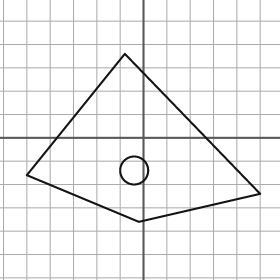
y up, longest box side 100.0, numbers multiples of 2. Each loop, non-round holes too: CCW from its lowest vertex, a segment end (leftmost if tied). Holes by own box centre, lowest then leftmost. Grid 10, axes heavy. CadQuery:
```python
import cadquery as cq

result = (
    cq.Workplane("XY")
    .moveTo(-2.0, -36.0)
    .lineTo(50.0, -24.0)
    .lineTo(-8.0, 36.0)
    .lineTo(-50.0, -16.0)
    .close()
    .moveTo(-4.0, -14.0)
    .circle(6.0)
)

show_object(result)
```